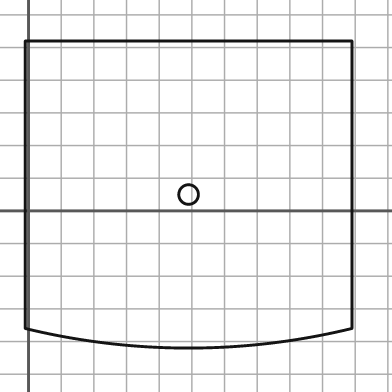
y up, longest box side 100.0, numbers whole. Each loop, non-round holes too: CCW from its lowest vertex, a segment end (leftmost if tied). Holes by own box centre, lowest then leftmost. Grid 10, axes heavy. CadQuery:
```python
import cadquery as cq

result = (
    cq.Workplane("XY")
    .moveTo(-1.0, -36.0)
    .threePointArc((49.0, -42.0), (99.0, -36.0))
    .lineTo(99.0, 52.0)
    .lineTo(-1.0, 52.0)
    .close()
    .moveTo(49.0, 5.0)
    .circle(3.0)
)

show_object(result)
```